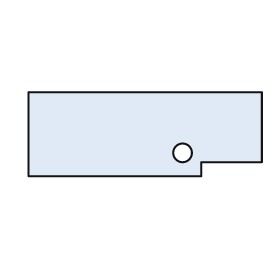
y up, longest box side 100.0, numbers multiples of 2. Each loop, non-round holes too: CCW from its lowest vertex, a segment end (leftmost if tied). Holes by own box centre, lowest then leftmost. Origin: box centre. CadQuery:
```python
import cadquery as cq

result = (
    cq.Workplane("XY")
    .moveTo(-50.0, -18.0)
    .lineTo(24.0, -18.0)
    .lineTo(24.0, -12.0)
    .lineTo(50.0, -12.0)
    .lineTo(50.0, 18.0)
    .lineTo(-50.0, 18.0)
    .close()
    .moveTo(16.0, -8.0)
    .circle(4.0)
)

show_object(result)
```